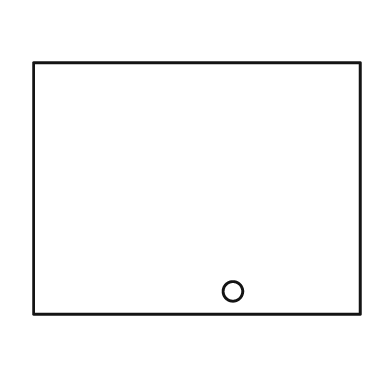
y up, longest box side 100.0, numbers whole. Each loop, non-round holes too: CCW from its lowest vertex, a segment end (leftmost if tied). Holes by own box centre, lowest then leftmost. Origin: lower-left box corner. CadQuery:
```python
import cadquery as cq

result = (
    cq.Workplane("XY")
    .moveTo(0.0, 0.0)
    .lineTo(100.0, 0.0)
    .lineTo(100.0, 77.0)
    .lineTo(0.0, 77.0)
    .close()
    .moveTo(61.0, 7.0)
    .circle(3.0)
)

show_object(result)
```